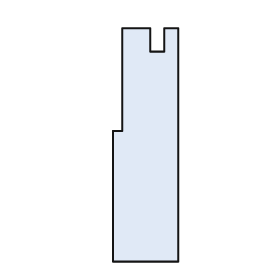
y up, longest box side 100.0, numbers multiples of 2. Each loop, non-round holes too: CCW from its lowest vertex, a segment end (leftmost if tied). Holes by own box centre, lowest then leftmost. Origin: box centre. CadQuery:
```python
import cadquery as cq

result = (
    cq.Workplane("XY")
    .moveTo(-14.0, -50.0)
    .lineTo(14.0, -50.0)
    .lineTo(14.0, 50.0)
    .lineTo(8.0, 50.0)
    .lineTo(8.0, 40.0)
    .lineTo(2.0, 40.0)
    .lineTo(2.0, 50.0)
    .lineTo(-10.0, 50.0)
    .lineTo(-10.0, 6.0)
    .lineTo(-14.0, 6.0)
    .close()
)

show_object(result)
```